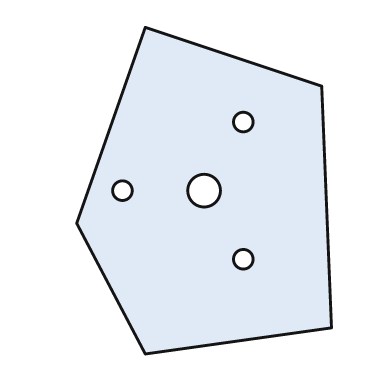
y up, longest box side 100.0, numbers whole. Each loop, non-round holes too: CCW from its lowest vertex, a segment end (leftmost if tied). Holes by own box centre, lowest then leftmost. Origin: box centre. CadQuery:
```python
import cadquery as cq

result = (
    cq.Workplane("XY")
    .moveTo(-18.0, -50.0)
    .lineTo(39.0, -42.0)
    .lineTo(36.0, 32.0)
    .lineTo(-18.0, 50.0)
    .lineTo(-39.0, -10.0)
    .close()
    .moveTo(12.0, -21.0)
    .circle(3.0)
    .moveTo(-25.0, 0.0)
    .circle(3.0)
    .moveTo(0.0, 0.0)
    .circle(5.0)
    .moveTo(12.0, 21.0)
    .circle(3.0)
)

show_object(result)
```